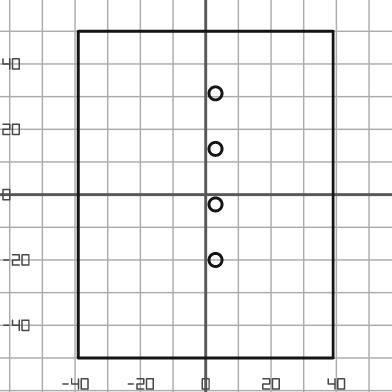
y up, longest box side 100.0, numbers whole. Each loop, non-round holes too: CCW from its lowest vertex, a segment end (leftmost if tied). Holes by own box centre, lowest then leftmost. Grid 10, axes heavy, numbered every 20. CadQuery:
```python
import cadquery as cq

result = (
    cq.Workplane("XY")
    .moveTo(-39.0, -50.0)
    .lineTo(39.0, -50.0)
    .lineTo(39.0, 50.0)
    .lineTo(-39.0, 50.0)
    .close()
    .moveTo(3.0, -20.0)
    .circle(2.0)
    .moveTo(3.0, -3.0)
    .circle(2.0)
    .moveTo(3.0, 14.0)
    .circle(2.0)
    .moveTo(3.0, 31.0)
    .circle(2.0)
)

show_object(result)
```